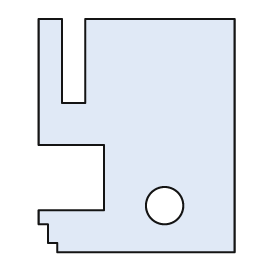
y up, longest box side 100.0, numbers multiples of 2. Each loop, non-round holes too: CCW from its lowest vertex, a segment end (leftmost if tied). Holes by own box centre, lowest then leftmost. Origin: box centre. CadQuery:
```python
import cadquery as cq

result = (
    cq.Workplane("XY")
    .moveTo(-34.0, -50.0)
    .lineTo(42.0, -50.0)
    .lineTo(42.0, 50.0)
    .lineTo(-22.0, 50.0)
    .lineTo(-22.0, 14.0)
    .lineTo(-32.0, 14.0)
    .lineTo(-32.0, 50.0)
    .lineTo(-42.0, 50.0)
    .lineTo(-42.0, -4.0)
    .lineTo(-14.0, -4.0)
    .lineTo(-14.0, -32.0)
    .lineTo(-42.0, -32.0)
    .lineTo(-42.0, -38.0)
    .lineTo(-38.0, -38.0)
    .lineTo(-38.0, -46.0)
    .lineTo(-34.0, -46.0)
    .close()
    .moveTo(12.0, -30.0)
    .circle(8.0)
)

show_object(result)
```